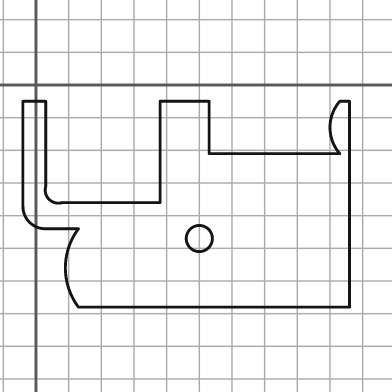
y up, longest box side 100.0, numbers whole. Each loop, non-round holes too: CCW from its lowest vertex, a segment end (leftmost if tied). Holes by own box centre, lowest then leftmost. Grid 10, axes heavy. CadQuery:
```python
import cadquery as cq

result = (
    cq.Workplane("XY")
    .moveTo(13.0, -68.0)
    .lineTo(96.0, -68.0)
    .lineTo(96.0, -5.0)
    .lineTo(93.0, -5.0)
    .threePointArc((90.0, -13.0), (93.0, -21.0))
    .lineTo(53.0, -21.0)
    .lineTo(53.0, -5.0)
    .lineTo(38.0, -5.0)
    .lineTo(38.0, -36.0)
    .lineTo(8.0, -36.0)
    .threePointArc((4.0, -35.0), (3.0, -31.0))
    .lineTo(3.0, -5.0)
    .lineTo(-4.0, -5.0)
    .lineTo(-4.0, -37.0)
    .threePointArc((-2.0, -42.0), (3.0, -44.0))
    .lineTo(13.0, -44.0)
    .threePointArc((9.0, -56.0), (13.0, -68.0))
    .close()
    .moveTo(50.0, -47.0)
    .circle(4.0)
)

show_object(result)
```